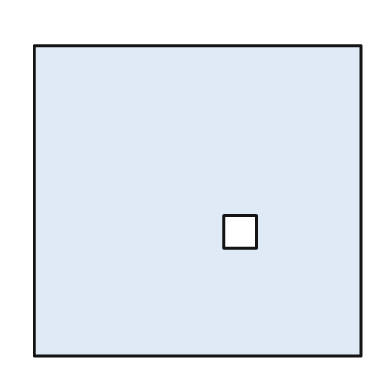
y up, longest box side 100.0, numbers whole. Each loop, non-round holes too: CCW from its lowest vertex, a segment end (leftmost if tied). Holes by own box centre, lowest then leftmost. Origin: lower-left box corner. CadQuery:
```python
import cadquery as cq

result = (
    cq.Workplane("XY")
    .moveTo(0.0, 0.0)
    .lineTo(100.0, 0.0)
    .lineTo(100.0, 95.0)
    .lineTo(0.0, 95.0)
    .close()
    .moveTo(58.0, 33.0)
    .lineTo(68.0, 33.0)
    .lineTo(68.0, 43.0)
    .lineTo(58.0, 43.0)
    .close()
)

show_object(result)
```